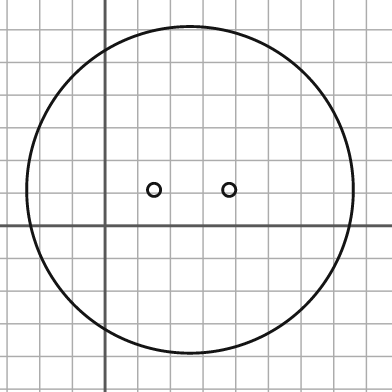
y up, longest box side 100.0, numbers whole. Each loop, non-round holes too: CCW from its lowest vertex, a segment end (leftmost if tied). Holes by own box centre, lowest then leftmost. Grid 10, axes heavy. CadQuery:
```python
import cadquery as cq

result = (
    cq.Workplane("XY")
    .moveTo(26.0, 11.0)
    .circle(50.0)
    .moveTo(15.0, 11.0)
    .circle(2.0)
    .moveTo(38.0, 11.0)
    .circle(2.0)
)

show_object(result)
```